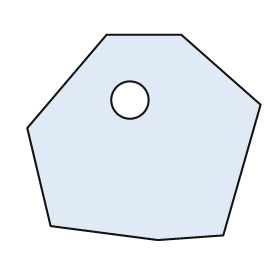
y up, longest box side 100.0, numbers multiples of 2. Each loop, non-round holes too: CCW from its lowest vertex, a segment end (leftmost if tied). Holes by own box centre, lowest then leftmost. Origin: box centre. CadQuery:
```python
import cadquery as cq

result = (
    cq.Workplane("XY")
    .moveTo(6.0, -44.0)
    .lineTo(34.0, -42.0)
    .lineTo(50.0, 14.0)
    .lineTo(16.0, 44.0)
    .lineTo(-16.0, 44.0)
    .lineTo(-50.0, 4.0)
    .lineTo(-40.0, -38.0)
    .close()
    .moveTo(-6.0, 16.0)
    .circle(8.0)
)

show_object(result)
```